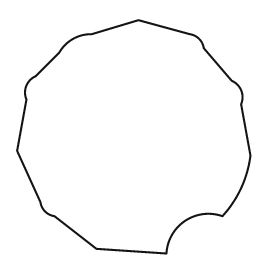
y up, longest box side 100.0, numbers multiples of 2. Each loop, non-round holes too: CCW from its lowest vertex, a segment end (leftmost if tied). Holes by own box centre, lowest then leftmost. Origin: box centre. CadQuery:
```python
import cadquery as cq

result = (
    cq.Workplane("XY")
    .moveTo(14.0, -50.0)
    .threePointArc((22.0, -36.0), (38.0, -34.0))
    .threePointArc((46.0, -22.0), (50.0, -8.0))
    .lineTo(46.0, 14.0)
    .threePointArc((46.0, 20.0), (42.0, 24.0))
    .lineTo(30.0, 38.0)
    .threePointArc((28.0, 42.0), (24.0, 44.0))
    .lineTo(2.0, 50.0)
    .lineTo(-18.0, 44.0)
    .threePointArc((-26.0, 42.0), (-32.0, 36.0))
    .lineTo(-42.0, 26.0)
    .threePointArc((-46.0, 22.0), (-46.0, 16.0))
    .lineTo(-50.0, -6.0)
    .lineTo(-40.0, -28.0)
    .threePointArc((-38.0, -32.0), (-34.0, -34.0))
    .lineTo(-16.0, -48.0)
    .close()
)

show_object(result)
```